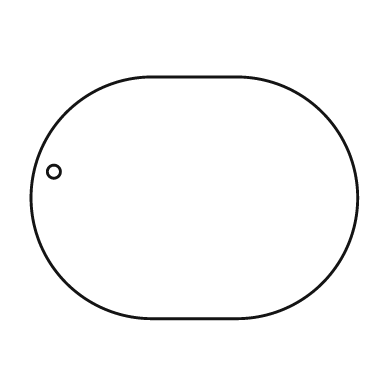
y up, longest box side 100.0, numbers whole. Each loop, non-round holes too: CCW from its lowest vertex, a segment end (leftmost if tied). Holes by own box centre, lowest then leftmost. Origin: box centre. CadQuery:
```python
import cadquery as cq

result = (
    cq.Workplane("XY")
    .moveTo(-13.0, -37.0)
    .lineTo(13.0, -37.0)
    .threePointArc((50.0, 0.0), (13.0, 37.0))
    .lineTo(-13.0, 37.0)
    .threePointArc((-50.0, 0.0), (-13.0, -37.0))
    .close()
    .moveTo(-43.0, 8.0)
    .circle(2.0)
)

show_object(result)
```